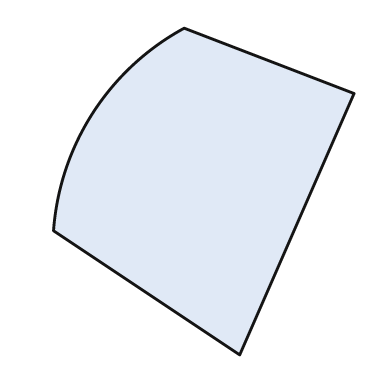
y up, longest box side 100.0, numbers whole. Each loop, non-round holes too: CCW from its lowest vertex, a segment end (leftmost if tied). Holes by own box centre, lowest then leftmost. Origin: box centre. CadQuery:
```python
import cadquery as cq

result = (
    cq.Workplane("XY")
    .moveTo(11.0, -50.0)
    .lineTo(46.0, 30.0)
    .lineTo(-6.0, 50.0)
    .threePointArc((-34.0, 24.0), (-46.0, -12.0))
    .close()
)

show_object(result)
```